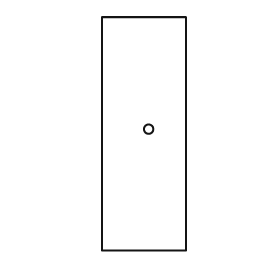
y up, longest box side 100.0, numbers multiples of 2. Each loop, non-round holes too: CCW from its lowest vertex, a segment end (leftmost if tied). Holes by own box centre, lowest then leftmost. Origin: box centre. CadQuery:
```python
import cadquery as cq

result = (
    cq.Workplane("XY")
    .moveTo(-18.0, -50.0)
    .lineTo(18.0, -50.0)
    .lineTo(18.0, 50.0)
    .lineTo(-18.0, 50.0)
    .close()
    .moveTo(2.0, 2.0)
    .circle(2.0)
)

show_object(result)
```